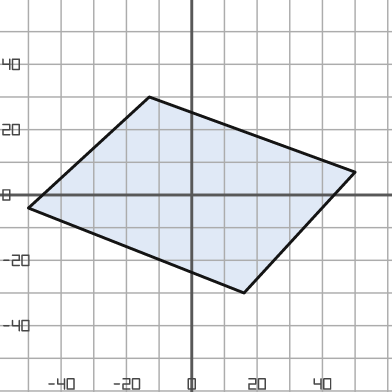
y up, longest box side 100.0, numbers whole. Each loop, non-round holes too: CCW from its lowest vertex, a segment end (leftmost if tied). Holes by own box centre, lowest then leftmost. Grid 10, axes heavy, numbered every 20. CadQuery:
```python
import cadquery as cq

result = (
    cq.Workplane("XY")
    .moveTo(16.0, -30.0)
    .lineTo(50.0, 7.0)
    .lineTo(-13.0, 30.0)
    .lineTo(-50.0, -4.0)
    .close()
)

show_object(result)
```